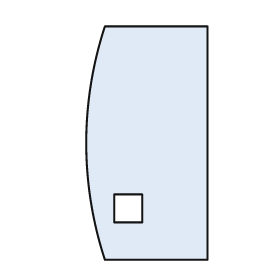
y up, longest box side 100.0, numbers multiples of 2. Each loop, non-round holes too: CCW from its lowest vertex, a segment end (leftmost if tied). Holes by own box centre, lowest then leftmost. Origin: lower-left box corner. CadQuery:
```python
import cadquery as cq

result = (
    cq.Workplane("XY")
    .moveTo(8.0, 0.0)
    .lineTo(52.0, 0.0)
    .lineTo(52.0, 100.0)
    .lineTo(8.0, 100.0)
    .threePointArc((0.0, 50.0), (8.0, 0.0))
    .close()
    .moveTo(12.0, 16.0)
    .lineTo(24.0, 16.0)
    .lineTo(24.0, 28.0)
    .lineTo(12.0, 28.0)
    .close()
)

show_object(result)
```